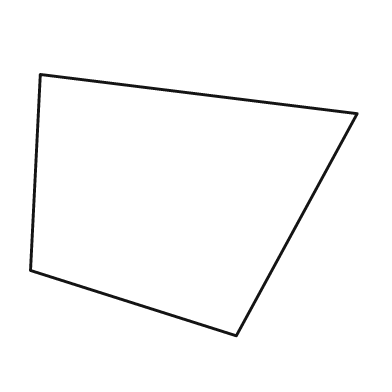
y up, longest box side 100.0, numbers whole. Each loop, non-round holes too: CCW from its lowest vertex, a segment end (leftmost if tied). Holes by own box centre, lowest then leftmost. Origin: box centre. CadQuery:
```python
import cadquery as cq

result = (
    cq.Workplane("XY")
    .moveTo(13.0, -40.0)
    .lineTo(50.0, 28.0)
    .lineTo(-47.0, 40.0)
    .lineTo(-50.0, -20.0)
    .close()
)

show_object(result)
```